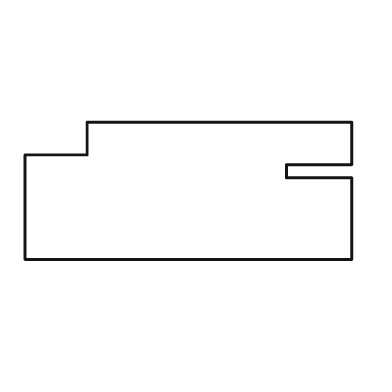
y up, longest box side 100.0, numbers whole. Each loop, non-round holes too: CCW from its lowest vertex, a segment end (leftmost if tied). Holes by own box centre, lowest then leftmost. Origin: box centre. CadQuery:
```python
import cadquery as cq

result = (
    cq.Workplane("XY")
    .moveTo(-50.0, -21.0)
    .lineTo(50.0, -21.0)
    .lineTo(50.0, 4.0)
    .lineTo(30.0, 4.0)
    .lineTo(30.0, 8.0)
    .lineTo(50.0, 8.0)
    .lineTo(50.0, 21.0)
    .lineTo(-31.0, 21.0)
    .lineTo(-31.0, 11.0)
    .lineTo(-50.0, 11.0)
    .close()
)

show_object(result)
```